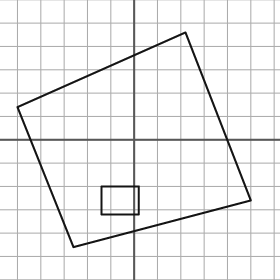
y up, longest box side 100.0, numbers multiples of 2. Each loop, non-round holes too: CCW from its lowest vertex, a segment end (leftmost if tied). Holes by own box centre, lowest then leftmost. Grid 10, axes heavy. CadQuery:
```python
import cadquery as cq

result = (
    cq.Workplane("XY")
    .moveTo(-26.0, -46.0)
    .lineTo(50.0, -26.0)
    .lineTo(22.0, 46.0)
    .lineTo(-50.0, 14.0)
    .close()
    .moveTo(-14.0, -32.0)
    .lineTo(2.0, -32.0)
    .lineTo(2.0, -20.0)
    .lineTo(-14.0, -20.0)
    .close()
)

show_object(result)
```